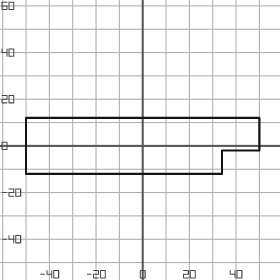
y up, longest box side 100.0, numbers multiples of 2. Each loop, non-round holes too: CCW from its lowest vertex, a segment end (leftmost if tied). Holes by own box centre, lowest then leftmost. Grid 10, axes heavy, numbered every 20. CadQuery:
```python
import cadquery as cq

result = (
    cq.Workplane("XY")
    .moveTo(-50.0, -12.0)
    .lineTo(34.0, -12.0)
    .lineTo(34.0, -2.0)
    .lineTo(50.0, -2.0)
    .lineTo(50.0, 12.0)
    .lineTo(-50.0, 12.0)
    .close()
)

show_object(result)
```